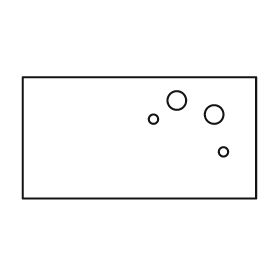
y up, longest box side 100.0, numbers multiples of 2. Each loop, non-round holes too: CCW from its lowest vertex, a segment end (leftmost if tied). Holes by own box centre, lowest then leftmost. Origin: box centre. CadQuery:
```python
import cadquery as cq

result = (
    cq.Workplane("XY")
    .moveTo(-50.0, -26.0)
    .lineTo(50.0, -26.0)
    .lineTo(50.0, 26.0)
    .lineTo(-50.0, 26.0)
    .close()
    .moveTo(36.0, -6.0)
    .circle(2.0)
    .moveTo(6.0, 8.0)
    .circle(2.0)
    .moveTo(32.0, 10.0)
    .circle(4.0)
    .moveTo(16.0, 16.0)
    .circle(4.0)
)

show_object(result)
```